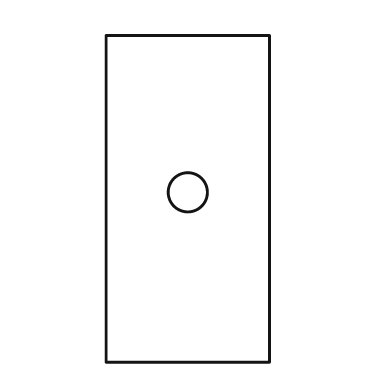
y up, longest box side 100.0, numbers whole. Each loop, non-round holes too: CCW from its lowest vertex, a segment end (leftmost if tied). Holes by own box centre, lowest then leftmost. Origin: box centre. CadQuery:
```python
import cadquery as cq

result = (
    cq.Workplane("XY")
    .moveTo(-25.0, -50.0)
    .lineTo(25.0, -50.0)
    .lineTo(25.0, 50.0)
    .lineTo(-25.0, 50.0)
    .close()
    .moveTo(0.0, 2.0)
    .circle(6.0)
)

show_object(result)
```